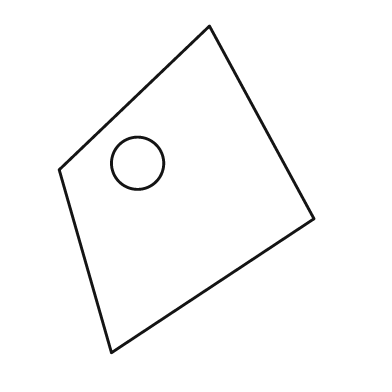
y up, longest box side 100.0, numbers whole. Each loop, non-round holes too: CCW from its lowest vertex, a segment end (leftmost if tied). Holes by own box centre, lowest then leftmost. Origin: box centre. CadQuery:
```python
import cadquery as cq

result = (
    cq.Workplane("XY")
    .moveTo(-23.0, -50.0)
    .lineTo(39.0, -9.0)
    .lineTo(7.0, 50.0)
    .lineTo(-39.0, 6.0)
    .close()
    .moveTo(-15.0, 8.0)
    .circle(8.0)
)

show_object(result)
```